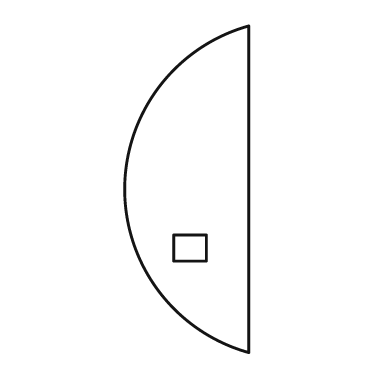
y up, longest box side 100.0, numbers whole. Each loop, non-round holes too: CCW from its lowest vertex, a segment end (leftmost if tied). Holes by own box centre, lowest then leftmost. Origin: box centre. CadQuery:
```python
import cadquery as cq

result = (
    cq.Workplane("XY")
    .moveTo(19.0, -50.0)
    .lineTo(19.0, 50.0)
    .threePointArc((-19.0, 0.0), (19.0, -50.0))
    .close()
    .moveTo(-4.0, -22.0)
    .lineTo(6.0, -22.0)
    .lineTo(6.0, -14.0)
    .lineTo(-4.0, -14.0)
    .close()
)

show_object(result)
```